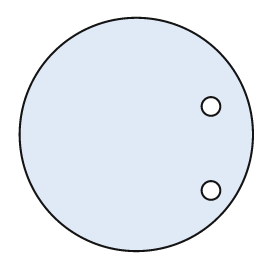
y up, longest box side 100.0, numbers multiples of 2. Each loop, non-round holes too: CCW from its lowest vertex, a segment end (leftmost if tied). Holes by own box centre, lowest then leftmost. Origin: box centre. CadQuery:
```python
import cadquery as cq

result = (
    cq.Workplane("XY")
    .moveTo(0.0, 0.0)
    .circle(50.0)
    .moveTo(32.0, -24.0)
    .circle(4.0)
    .moveTo(32.0, 12.0)
    .circle(4.0)
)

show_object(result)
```